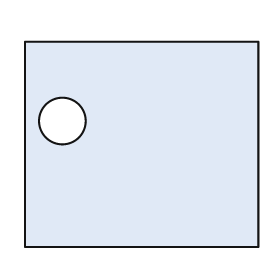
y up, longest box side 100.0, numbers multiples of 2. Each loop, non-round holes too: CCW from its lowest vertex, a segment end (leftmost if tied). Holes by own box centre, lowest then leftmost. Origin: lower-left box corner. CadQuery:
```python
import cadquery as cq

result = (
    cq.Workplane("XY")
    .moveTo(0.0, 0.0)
    .lineTo(100.0, 0.0)
    .lineTo(100.0, 88.0)
    .lineTo(0.0, 88.0)
    .close()
    .moveTo(16.0, 54.0)
    .circle(10.0)
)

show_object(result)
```